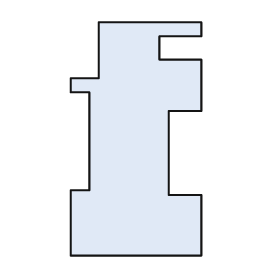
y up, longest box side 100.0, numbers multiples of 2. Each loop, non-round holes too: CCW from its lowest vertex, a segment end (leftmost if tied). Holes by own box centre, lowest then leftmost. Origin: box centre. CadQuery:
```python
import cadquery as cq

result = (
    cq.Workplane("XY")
    .moveTo(-28.0, -50.0)
    .lineTo(28.0, -50.0)
    .lineTo(28.0, -24.0)
    .lineTo(14.0, -24.0)
    .lineTo(14.0, 12.0)
    .lineTo(28.0, 12.0)
    .lineTo(28.0, 34.0)
    .lineTo(10.0, 34.0)
    .lineTo(10.0, 44.0)
    .lineTo(28.0, 44.0)
    .lineTo(28.0, 50.0)
    .lineTo(-16.0, 50.0)
    .lineTo(-16.0, 26.0)
    .lineTo(-28.0, 26.0)
    .lineTo(-28.0, 20.0)
    .lineTo(-20.0, 20.0)
    .lineTo(-20.0, -22.0)
    .lineTo(-28.0, -22.0)
    .close()
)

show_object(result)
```